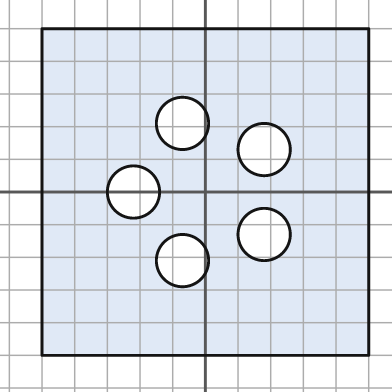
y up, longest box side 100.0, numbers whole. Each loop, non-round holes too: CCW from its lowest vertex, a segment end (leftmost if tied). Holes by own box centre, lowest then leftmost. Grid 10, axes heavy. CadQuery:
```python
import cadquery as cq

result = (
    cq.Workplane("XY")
    .moveTo(-50.0, -50.0)
    .lineTo(50.0, -50.0)
    .lineTo(50.0, 50.0)
    .lineTo(-50.0, 50.0)
    .close()
    .moveTo(-7.0, -21.0)
    .circle(8.0)
    .moveTo(18.0, -13.0)
    .circle(8.0)
    .moveTo(-22.0, 0.0)
    .circle(8.0)
    .moveTo(18.0, 13.0)
    .circle(8.0)
    .moveTo(-7.0, 21.0)
    .circle(8.0)
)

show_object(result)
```